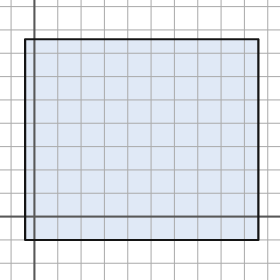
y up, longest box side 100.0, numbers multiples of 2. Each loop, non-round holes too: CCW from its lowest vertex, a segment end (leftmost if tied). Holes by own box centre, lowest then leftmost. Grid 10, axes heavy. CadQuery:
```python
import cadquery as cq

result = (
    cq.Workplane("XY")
    .moveTo(-4.0, -10.0)
    .lineTo(96.0, -10.0)
    .lineTo(96.0, 76.0)
    .lineTo(-4.0, 76.0)
    .close()
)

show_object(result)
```